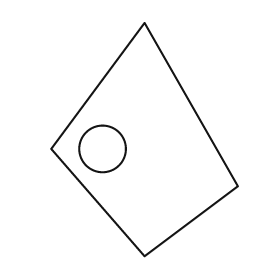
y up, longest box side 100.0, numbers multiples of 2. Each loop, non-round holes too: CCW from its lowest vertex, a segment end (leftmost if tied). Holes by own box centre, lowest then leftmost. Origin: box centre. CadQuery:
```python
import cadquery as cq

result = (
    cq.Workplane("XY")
    .moveTo(0.0, -50.0)
    .lineTo(40.0, -20.0)
    .lineTo(0.0, 50.0)
    .lineTo(-40.0, -4.0)
    .close()
    .moveTo(-18.0, -4.0)
    .circle(10.0)
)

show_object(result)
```